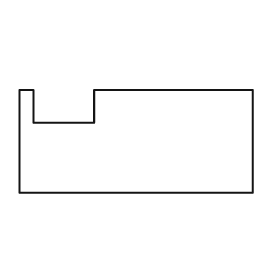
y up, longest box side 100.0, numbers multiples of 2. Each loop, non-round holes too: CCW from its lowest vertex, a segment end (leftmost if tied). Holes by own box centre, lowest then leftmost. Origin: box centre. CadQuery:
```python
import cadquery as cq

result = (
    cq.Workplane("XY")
    .moveTo(-50.0, -22.0)
    .lineTo(50.0, -22.0)
    .lineTo(50.0, 22.0)
    .lineTo(-18.0, 22.0)
    .lineTo(-18.0, 8.0)
    .lineTo(-44.0, 8.0)
    .lineTo(-44.0, 22.0)
    .lineTo(-50.0, 22.0)
    .close()
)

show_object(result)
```